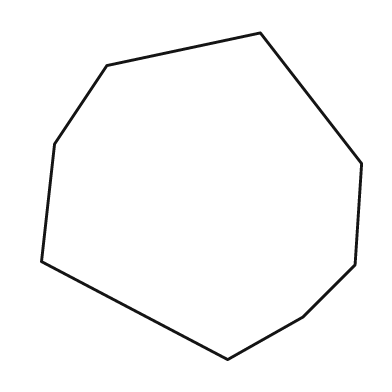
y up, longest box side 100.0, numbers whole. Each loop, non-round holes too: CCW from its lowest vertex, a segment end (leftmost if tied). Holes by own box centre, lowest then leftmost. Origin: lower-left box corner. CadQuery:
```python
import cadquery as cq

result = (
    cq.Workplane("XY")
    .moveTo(57.0, 0.0)
    .lineTo(80.0, 13.0)
    .lineTo(96.0, 29.0)
    .lineTo(98.0, 60.0)
    .lineTo(67.0, 100.0)
    .lineTo(20.0, 90.0)
    .lineTo(4.0, 66.0)
    .lineTo(0.0, 30.0)
    .close()
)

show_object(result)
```